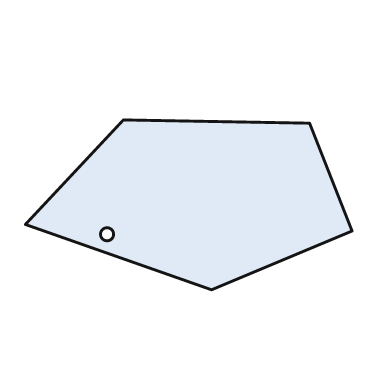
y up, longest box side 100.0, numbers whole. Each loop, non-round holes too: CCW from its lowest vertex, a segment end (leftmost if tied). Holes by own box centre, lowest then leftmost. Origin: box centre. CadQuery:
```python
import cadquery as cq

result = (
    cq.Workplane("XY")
    .moveTo(7.0, -26.0)
    .lineTo(50.0, -8.0)
    .lineTo(37.0, 25.0)
    .lineTo(-20.0, 26.0)
    .lineTo(-50.0, -6.0)
    .close()
    .moveTo(-25.0, -9.0)
    .circle(2.0)
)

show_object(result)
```